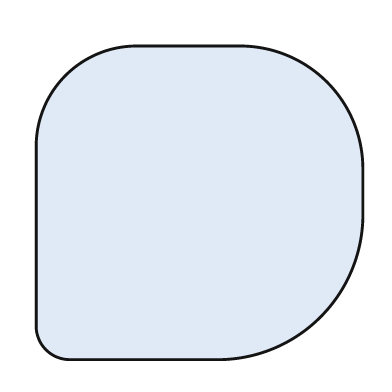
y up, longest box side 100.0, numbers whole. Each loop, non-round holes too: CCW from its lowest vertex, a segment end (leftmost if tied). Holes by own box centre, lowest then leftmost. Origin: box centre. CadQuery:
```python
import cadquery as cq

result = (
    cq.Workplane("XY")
    .moveTo(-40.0, -48.0)
    .lineTo(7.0, -48.0)
    .threePointArc((37.0, -35.0), (50.0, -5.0))
    .lineTo(50.0, 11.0)
    .threePointArc((39.0, 37.0), (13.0, 48.0))
    .lineTo(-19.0, 48.0)
    .threePointArc((-41.0, 39.0), (-50.0, 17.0))
    .lineTo(-50.0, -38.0)
    .threePointArc((-47.0, -45.0), (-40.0, -48.0))
    .close()
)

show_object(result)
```